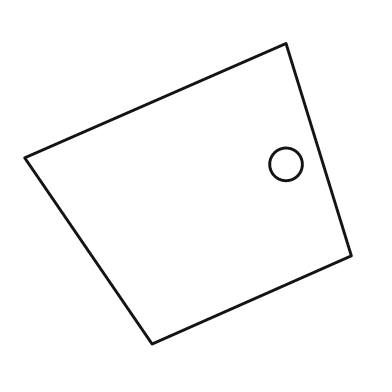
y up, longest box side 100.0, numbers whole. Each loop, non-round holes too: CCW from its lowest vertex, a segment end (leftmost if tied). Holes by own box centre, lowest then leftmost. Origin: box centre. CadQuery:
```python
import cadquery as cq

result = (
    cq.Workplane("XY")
    .moveTo(-11.0, -46.0)
    .lineTo(50.0, -19.0)
    .lineTo(30.0, 46.0)
    .lineTo(-50.0, 11.0)
    .close()
    .moveTo(30.0, 9.0)
    .circle(5.0)
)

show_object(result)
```